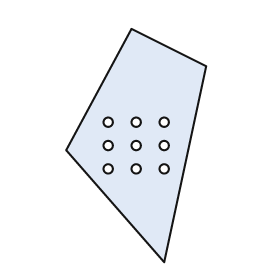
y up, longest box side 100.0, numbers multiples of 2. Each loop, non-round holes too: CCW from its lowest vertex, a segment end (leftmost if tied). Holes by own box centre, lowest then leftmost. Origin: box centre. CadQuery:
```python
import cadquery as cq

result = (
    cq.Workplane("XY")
    .moveTo(12.0, -50.0)
    .lineTo(30.0, 34.0)
    .lineTo(-2.0, 50.0)
    .lineTo(-30.0, -2.0)
    .close()
    .moveTo(-12.0, -10.0)
    .circle(2.0)
    .moveTo(0.0, -10.0)
    .circle(2.0)
    .moveTo(12.0, -10.0)
    .circle(2.0)
    .moveTo(-12.0, 0.0)
    .circle(2.0)
    .moveTo(0.0, 0.0)
    .circle(2.0)
    .moveTo(12.0, 0.0)
    .circle(2.0)
    .moveTo(-12.0, 10.0)
    .circle(2.0)
    .moveTo(0.0, 10.0)
    .circle(2.0)
    .moveTo(12.0, 10.0)
    .circle(2.0)
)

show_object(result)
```